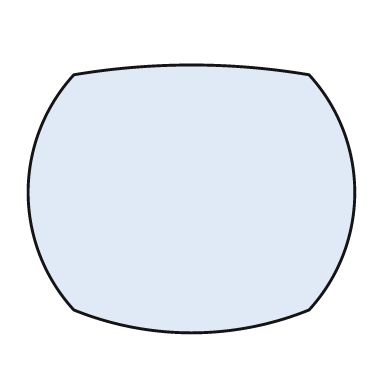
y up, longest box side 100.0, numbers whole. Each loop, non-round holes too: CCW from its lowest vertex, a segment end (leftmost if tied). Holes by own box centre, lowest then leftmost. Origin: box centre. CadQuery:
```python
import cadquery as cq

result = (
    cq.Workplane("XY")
    .moveTo(-36.0, -34.0)
    .threePointArc((0.0, -41.0), (36.0, -34.0))
    .threePointArc((50.0, 2.0), (36.0, 38.0))
    .threePointArc((0.0, 41.0), (-36.0, 38.0))
    .threePointArc((-50.0, 2.0), (-36.0, -34.0))
    .close()
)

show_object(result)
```